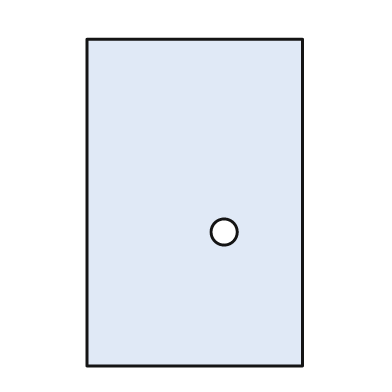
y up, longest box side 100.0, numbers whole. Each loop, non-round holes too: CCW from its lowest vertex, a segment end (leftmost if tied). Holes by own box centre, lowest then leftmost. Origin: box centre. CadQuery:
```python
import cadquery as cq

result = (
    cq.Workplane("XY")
    .moveTo(-33.0, -50.0)
    .lineTo(33.0, -50.0)
    .lineTo(33.0, 50.0)
    .lineTo(-33.0, 50.0)
    .close()
    .moveTo(9.0, -9.0)
    .circle(4.0)
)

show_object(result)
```